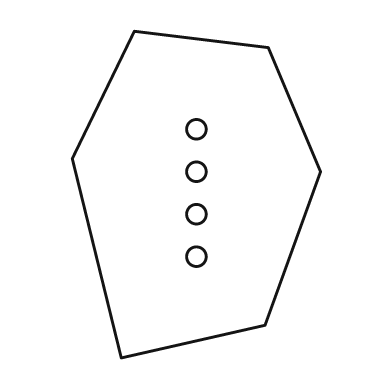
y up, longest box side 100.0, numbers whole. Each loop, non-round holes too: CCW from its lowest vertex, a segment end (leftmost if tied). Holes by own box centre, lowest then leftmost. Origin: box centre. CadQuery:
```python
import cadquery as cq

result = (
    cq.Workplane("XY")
    .moveTo(-23.0, -50.0)
    .lineTo(21.0, -40.0)
    .lineTo(38.0, 7.0)
    .lineTo(22.0, 45.0)
    .lineTo(-19.0, 50.0)
    .lineTo(-38.0, 11.0)
    .close()
    .moveTo(0.0, -19.0)
    .circle(3.0)
    .moveTo(0.0, -6.0)
    .circle(3.0)
    .moveTo(0.0, 7.0)
    .circle(3.0)
    .moveTo(0.0, 20.0)
    .circle(3.0)
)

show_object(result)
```